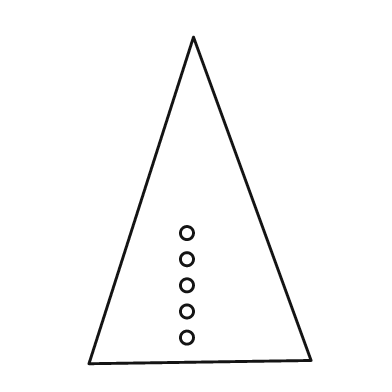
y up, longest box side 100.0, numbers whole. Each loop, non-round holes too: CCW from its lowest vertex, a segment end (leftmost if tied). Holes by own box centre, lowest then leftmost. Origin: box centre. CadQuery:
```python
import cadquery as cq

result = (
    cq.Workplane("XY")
    .moveTo(-34.0, -50.0)
    .lineTo(34.0, -49.0)
    .lineTo(-2.0, 50.0)
    .close()
    .moveTo(-4.0, -42.0)
    .circle(2.0)
    .moveTo(-4.0, -34.0)
    .circle(2.0)
    .moveTo(-4.0, -26.0)
    .circle(2.0)
    .moveTo(-4.0, -18.0)
    .circle(2.0)
    .moveTo(-4.0, -10.0)
    .circle(2.0)
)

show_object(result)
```